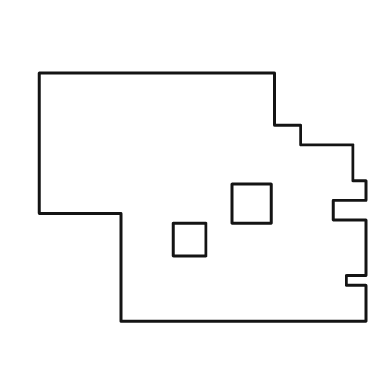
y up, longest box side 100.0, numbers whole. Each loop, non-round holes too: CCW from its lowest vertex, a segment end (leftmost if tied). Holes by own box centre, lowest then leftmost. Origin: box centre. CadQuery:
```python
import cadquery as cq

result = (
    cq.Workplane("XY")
    .moveTo(-25.0, -38.0)
    .lineTo(50.0, -38.0)
    .lineTo(50.0, -27.0)
    .lineTo(44.0, -27.0)
    .lineTo(44.0, -24.0)
    .lineTo(50.0, -24.0)
    .lineTo(50.0, -7.0)
    .lineTo(40.0, -7.0)
    .lineTo(40.0, -1.0)
    .lineTo(50.0, -1.0)
    .lineTo(50.0, 5.0)
    .lineTo(46.0, 5.0)
    .lineTo(46.0, 16.0)
    .lineTo(30.0, 16.0)
    .lineTo(30.0, 22.0)
    .lineTo(22.0, 22.0)
    .lineTo(22.0, 38.0)
    .lineTo(-50.0, 38.0)
    .lineTo(-50.0, -5.0)
    .lineTo(-25.0, -5.0)
    .close()
    .moveTo(-9.0, -18.0)
    .lineTo(1.0, -18.0)
    .lineTo(1.0, -8.0)
    .lineTo(-9.0, -8.0)
    .close()
    .moveTo(9.0, -8.0)
    .lineTo(21.0, -8.0)
    .lineTo(21.0, 4.0)
    .lineTo(9.0, 4.0)
    .close()
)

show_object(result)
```